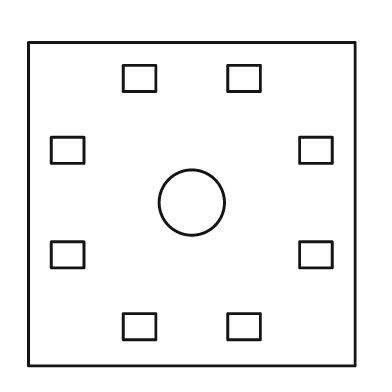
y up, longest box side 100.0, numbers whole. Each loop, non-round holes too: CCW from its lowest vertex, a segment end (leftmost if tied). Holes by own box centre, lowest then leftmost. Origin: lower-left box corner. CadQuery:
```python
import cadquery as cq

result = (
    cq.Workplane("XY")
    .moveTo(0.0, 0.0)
    .lineTo(100.0, 0.0)
    .lineTo(100.0, 99.0)
    .lineTo(0.0, 99.0)
    .close()
    .moveTo(29.0, 8.0)
    .lineTo(39.0, 8.0)
    .lineTo(39.0, 16.0)
    .lineTo(29.0, 16.0)
    .close()
    .moveTo(61.0, 8.0)
    .lineTo(71.0, 8.0)
    .lineTo(71.0, 16.0)
    .lineTo(61.0, 16.0)
    .close()
    .moveTo(7.0, 30.0)
    .lineTo(17.0, 30.0)
    .lineTo(17.0, 38.0)
    .lineTo(7.0, 38.0)
    .close()
    .moveTo(83.0, 30.0)
    .lineTo(93.0, 30.0)
    .lineTo(93.0, 38.0)
    .lineTo(83.0, 38.0)
    .close()
    .moveTo(50.0, 50.0)
    .circle(10.0)
    .moveTo(7.0, 62.0)
    .lineTo(17.0, 62.0)
    .lineTo(17.0, 70.0)
    .lineTo(7.0, 70.0)
    .close()
    .moveTo(83.0, 62.0)
    .lineTo(93.0, 62.0)
    .lineTo(93.0, 70.0)
    .lineTo(83.0, 70.0)
    .close()
    .moveTo(29.0, 84.0)
    .lineTo(39.0, 84.0)
    .lineTo(39.0, 92.0)
    .lineTo(29.0, 92.0)
    .close()
    .moveTo(61.0, 84.0)
    .lineTo(71.0, 84.0)
    .lineTo(71.0, 92.0)
    .lineTo(61.0, 92.0)
    .close()
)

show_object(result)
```